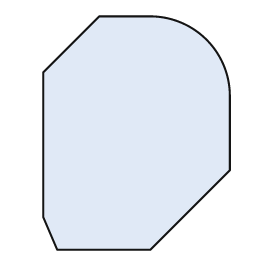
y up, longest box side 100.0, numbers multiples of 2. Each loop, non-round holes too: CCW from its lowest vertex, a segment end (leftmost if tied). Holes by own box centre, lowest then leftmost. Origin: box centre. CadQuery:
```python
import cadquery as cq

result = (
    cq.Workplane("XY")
    .moveTo(-34.0, -50.0)
    .lineTo(6.0, -50.0)
    .lineTo(40.0, -16.0)
    .lineTo(40.0, 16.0)
    .threePointArc((30.0, 40.0), (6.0, 50.0))
    .lineTo(-16.0, 50.0)
    .lineTo(-40.0, 26.0)
    .lineTo(-40.0, -36.0)
    .close()
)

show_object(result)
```